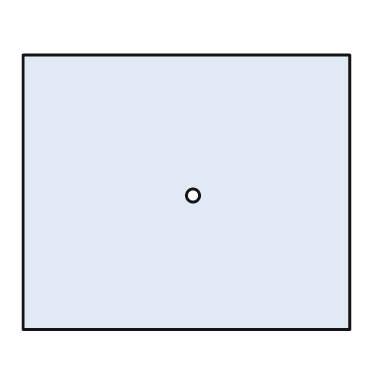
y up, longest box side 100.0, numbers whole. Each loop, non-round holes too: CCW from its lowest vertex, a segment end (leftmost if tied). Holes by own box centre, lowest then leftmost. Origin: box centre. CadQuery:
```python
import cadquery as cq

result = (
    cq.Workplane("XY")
    .moveTo(-50.0, -42.0)
    .lineTo(50.0, -42.0)
    .lineTo(50.0, 42.0)
    .lineTo(-50.0, 42.0)
    .close()
    .moveTo(2.0, -1.0)
    .circle(2.0)
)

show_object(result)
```